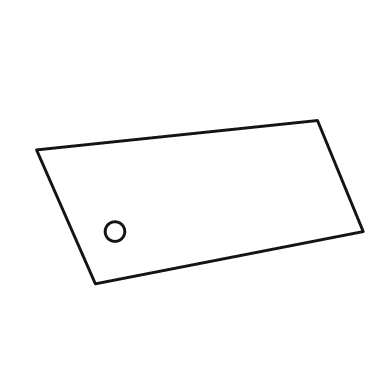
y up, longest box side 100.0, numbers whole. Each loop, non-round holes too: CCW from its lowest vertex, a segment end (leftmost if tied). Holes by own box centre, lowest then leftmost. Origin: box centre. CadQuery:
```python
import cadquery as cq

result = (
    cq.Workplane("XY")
    .moveTo(-32.0, -25.0)
    .lineTo(50.0, -9.0)
    .lineTo(36.0, 25.0)
    .lineTo(-50.0, 16.0)
    .close()
    .moveTo(-26.0, -9.0)
    .circle(3.0)
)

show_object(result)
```